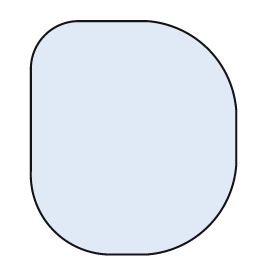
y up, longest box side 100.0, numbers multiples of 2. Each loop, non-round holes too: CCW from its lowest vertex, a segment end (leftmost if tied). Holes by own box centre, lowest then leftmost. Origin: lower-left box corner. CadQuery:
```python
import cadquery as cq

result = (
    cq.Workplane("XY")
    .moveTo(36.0, 0.0)
    .lineTo(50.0, 0.0)
    .threePointArc((76.0, 12.0), (88.0, 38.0))
    .lineTo(88.0, 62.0)
    .threePointArc((76.0, 88.0), (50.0, 100.0))
    .lineTo(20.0, 100.0)
    .threePointArc((6.0, 94.0), (0.0, 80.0))
    .lineTo(0.0, 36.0)
    .threePointArc((10.0, 10.0), (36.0, 0.0))
    .close()
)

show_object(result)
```